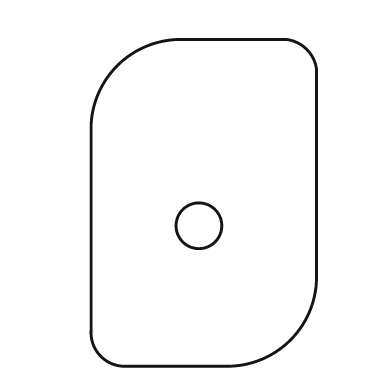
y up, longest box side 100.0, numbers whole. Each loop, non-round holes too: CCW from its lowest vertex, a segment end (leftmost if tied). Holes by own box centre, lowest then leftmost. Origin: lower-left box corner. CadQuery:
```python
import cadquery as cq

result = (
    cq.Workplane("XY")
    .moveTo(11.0, 0.0)
    .lineTo(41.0, 0.0)
    .threePointArc((61.0, 8.0), (69.0, 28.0))
    .lineTo(69.0, 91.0)
    .threePointArc((66.0, 97.0), (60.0, 100.0))
    .lineTo(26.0, 100.0)
    .threePointArc((8.0, 92.0), (0.0, 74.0))
    .lineTo(0.0, 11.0)
    .threePointArc((3.0, 3.0), (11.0, 0.0))
    .close()
    .moveTo(33.0, 43.0)
    .circle(7.0)
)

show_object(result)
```